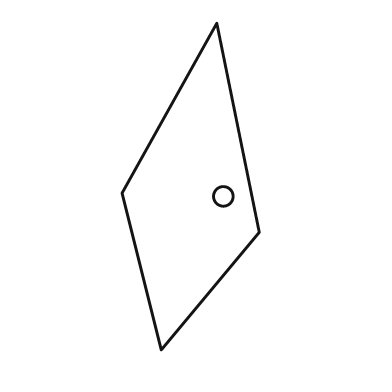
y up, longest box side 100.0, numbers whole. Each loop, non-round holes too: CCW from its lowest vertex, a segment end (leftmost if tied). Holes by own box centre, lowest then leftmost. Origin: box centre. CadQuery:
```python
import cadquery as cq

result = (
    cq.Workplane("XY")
    .moveTo(-9.0, -50.0)
    .lineTo(21.0, -14.0)
    .lineTo(8.0, 50.0)
    .lineTo(-21.0, -2.0)
    .close()
    .moveTo(10.0, -3.0)
    .circle(3.0)
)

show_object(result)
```